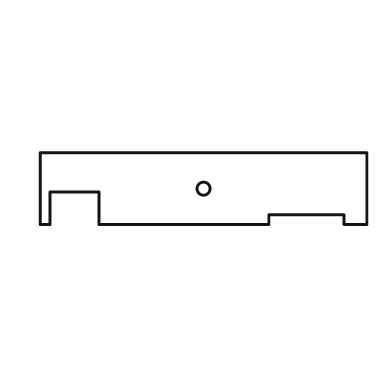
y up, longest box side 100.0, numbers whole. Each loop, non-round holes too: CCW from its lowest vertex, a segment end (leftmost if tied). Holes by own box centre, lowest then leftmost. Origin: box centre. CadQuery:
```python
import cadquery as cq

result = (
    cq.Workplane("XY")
    .moveTo(-50.0, -11.0)
    .lineTo(-47.0, -11.0)
    .lineTo(-47.0, -1.0)
    .lineTo(-32.0, -1.0)
    .lineTo(-32.0, -11.0)
    .lineTo(20.0, -11.0)
    .lineTo(20.0, -8.0)
    .lineTo(43.0, -8.0)
    .lineTo(43.0, -11.0)
    .lineTo(50.0, -11.0)
    .lineTo(50.0, 11.0)
    .lineTo(-50.0, 11.0)
    .close()
    .moveTo(0.0, 0.0)
    .circle(2.0)
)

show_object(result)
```